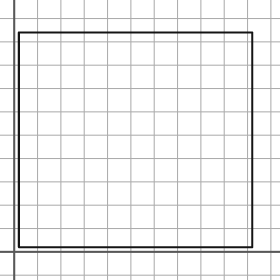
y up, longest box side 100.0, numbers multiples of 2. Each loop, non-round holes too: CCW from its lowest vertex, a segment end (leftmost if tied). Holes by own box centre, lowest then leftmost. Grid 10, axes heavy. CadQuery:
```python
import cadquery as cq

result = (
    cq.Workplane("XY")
    .moveTo(2.0, 2.0)
    .lineTo(102.0, 2.0)
    .lineTo(102.0, 94.0)
    .lineTo(2.0, 94.0)
    .close()
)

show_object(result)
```